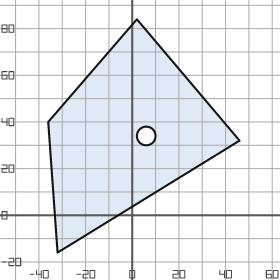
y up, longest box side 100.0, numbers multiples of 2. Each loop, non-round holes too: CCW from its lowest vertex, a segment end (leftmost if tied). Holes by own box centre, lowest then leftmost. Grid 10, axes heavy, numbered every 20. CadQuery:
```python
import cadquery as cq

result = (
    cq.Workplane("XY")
    .moveTo(-32.0, -16.0)
    .lineTo(46.0, 32.0)
    .lineTo(2.0, 84.0)
    .lineTo(-36.0, 40.0)
    .close()
    .moveTo(6.0, 34.0)
    .circle(4.0)
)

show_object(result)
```